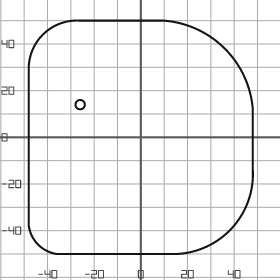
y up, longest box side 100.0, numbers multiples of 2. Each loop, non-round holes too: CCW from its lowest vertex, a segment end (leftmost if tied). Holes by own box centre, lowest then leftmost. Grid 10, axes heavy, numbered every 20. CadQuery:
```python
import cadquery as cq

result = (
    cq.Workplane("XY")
    .moveTo(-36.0, -50.0)
    .lineTo(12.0, -50.0)
    .threePointArc((38.0, -40.0), (48.0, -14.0))
    .lineTo(48.0, 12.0)
    .threePointArc((36.0, 38.0), (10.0, 50.0))
    .lineTo(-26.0, 50.0)
    .threePointArc((-42.0, 44.0), (-48.0, 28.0))
    .lineTo(-48.0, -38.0)
    .threePointArc((-44.0, -46.0), (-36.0, -50.0))
    .close()
    .moveTo(-26.0, 14.0)
    .circle(2.0)
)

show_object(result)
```